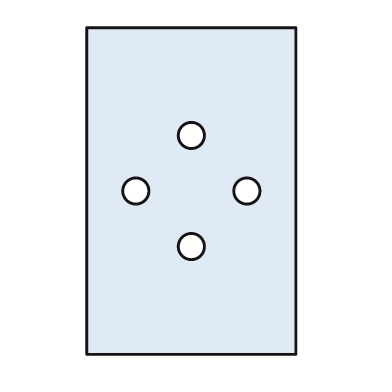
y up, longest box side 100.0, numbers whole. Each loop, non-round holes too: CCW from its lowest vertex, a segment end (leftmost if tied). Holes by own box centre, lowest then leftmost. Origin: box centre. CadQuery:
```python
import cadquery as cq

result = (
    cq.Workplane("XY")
    .moveTo(-32.0, -50.0)
    .lineTo(32.0, -50.0)
    .lineTo(32.0, 50.0)
    .lineTo(-32.0, 50.0)
    .close()
    .moveTo(0.0, -17.0)
    .circle(4.0)
    .moveTo(-17.0, 0.0)
    .circle(4.0)
    .moveTo(17.0, 0.0)
    .circle(4.0)
    .moveTo(0.0, 17.0)
    .circle(4.0)
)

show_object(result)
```